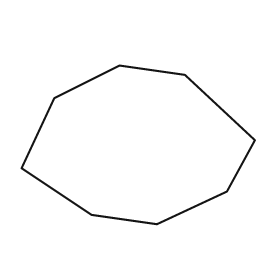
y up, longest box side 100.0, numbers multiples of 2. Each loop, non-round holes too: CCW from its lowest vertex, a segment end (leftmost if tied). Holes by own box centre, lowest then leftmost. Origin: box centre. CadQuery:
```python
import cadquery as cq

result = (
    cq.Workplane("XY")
    .moveTo(8.0, -34.0)
    .lineTo(38.0, -20.0)
    .lineTo(50.0, 2.0)
    .lineTo(20.0, 30.0)
    .lineTo(-8.0, 34.0)
    .lineTo(-36.0, 20.0)
    .lineTo(-50.0, -10.0)
    .lineTo(-20.0, -30.0)
    .close()
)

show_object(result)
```